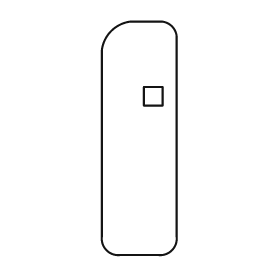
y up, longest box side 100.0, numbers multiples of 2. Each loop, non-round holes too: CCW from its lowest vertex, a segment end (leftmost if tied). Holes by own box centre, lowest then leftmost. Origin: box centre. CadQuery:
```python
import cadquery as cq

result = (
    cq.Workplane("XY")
    .moveTo(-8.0, -50.0)
    .lineTo(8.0, -50.0)
    .threePointArc((14.0, -48.0), (16.0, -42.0))
    .lineTo(16.0, 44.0)
    .threePointArc((14.0, 48.0), (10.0, 50.0))
    .lineTo(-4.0, 50.0)
    .threePointArc((-12.0, 46.0), (-16.0, 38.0))
    .lineTo(-16.0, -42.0)
    .threePointArc((-14.0, -48.0), (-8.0, -50.0))
    .close()
    .moveTo(2.0, 14.0)
    .lineTo(10.0, 14.0)
    .lineTo(10.0, 22.0)
    .lineTo(2.0, 22.0)
    .close()
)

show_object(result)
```